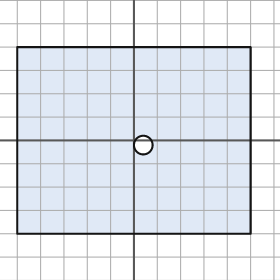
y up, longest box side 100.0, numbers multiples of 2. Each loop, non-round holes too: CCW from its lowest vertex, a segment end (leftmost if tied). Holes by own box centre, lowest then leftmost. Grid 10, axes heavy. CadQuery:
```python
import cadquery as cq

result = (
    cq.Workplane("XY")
    .moveTo(-50.0, -40.0)
    .lineTo(50.0, -40.0)
    .lineTo(50.0, 40.0)
    .lineTo(-50.0, 40.0)
    .close()
    .moveTo(4.0, -2.0)
    .circle(4.0)
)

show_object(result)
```